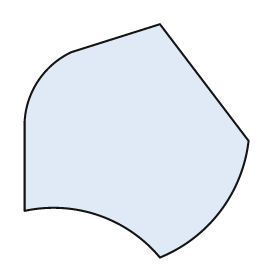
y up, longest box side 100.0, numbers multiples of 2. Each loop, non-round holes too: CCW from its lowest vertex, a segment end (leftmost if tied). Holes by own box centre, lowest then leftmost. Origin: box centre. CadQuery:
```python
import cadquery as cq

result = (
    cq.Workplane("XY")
    .moveTo(10.0, -50.0)
    .threePointArc((36.0, -30.0), (48.0, 0.0))
    .lineTo(10.0, 50.0)
    .lineTo(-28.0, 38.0)
    .threePointArc((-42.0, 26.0), (-48.0, 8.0))
    .lineTo(-48.0, -30.0)
    .threePointArc((-16.0, -32.0), (10.0, -50.0))
    .close()
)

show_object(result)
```